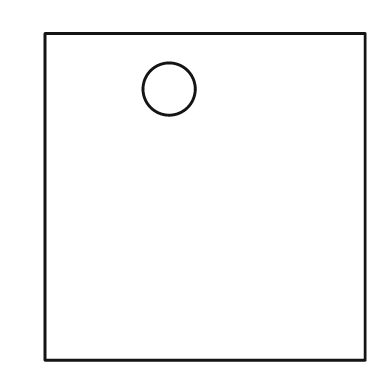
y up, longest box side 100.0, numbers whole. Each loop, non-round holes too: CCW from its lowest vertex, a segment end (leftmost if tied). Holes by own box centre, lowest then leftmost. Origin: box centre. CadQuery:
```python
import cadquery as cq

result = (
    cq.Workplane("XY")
    .moveTo(-49.0, -50.0)
    .lineTo(49.0, -50.0)
    .lineTo(49.0, 50.0)
    .lineTo(-49.0, 50.0)
    .close()
    .moveTo(-11.0, 33.0)
    .circle(8.0)
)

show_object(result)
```